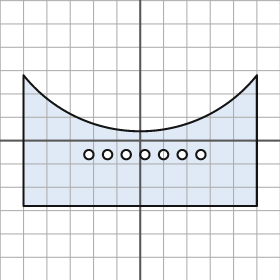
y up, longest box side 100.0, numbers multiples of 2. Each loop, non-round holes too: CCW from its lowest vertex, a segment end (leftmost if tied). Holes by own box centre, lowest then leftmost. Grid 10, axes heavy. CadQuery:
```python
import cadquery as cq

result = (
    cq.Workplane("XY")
    .moveTo(-50.0, -28.0)
    .lineTo(50.0, -28.0)
    .lineTo(50.0, 28.0)
    .threePointArc((0.0, 4.0), (-50.0, 28.0))
    .close()
    .moveTo(-22.0, -6.0)
    .circle(2.0)
    .moveTo(-14.0, -6.0)
    .circle(2.0)
    .moveTo(-6.0, -6.0)
    .circle(2.0)
    .moveTo(2.0, -6.0)
    .circle(2.0)
    .moveTo(10.0, -6.0)
    .circle(2.0)
    .moveTo(18.0, -6.0)
    .circle(2.0)
    .moveTo(26.0, -6.0)
    .circle(2.0)
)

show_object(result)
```